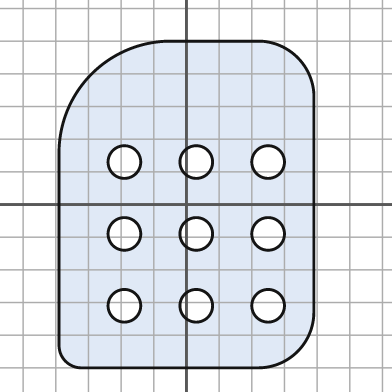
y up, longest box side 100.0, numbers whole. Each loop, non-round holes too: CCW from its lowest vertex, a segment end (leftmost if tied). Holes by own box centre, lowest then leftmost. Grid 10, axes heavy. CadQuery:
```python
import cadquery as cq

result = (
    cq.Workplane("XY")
    .moveTo(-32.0, -50.0)
    .lineTo(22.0, -50.0)
    .threePointArc((34.0, -45.0), (39.0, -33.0))
    .lineTo(39.0, 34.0)
    .threePointArc((34.0, 45.0), (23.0, 50.0))
    .lineTo(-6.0, 50.0)
    .threePointArc((-29.0, 40.0), (-39.0, 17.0))
    .lineTo(-39.0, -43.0)
    .threePointArc((-37.0, -48.0), (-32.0, -50.0))
    .close()
    .moveTo(-19.0, -31.0)
    .circle(5.0)
    .moveTo(3.0, -31.0)
    .circle(5.0)
    .moveTo(25.0, -31.0)
    .circle(5.0)
    .moveTo(-19.0, -9.0)
    .circle(5.0)
    .moveTo(3.0, -9.0)
    .circle(5.0)
    .moveTo(25.0, -9.0)
    .circle(5.0)
    .moveTo(-19.0, 13.0)
    .circle(5.0)
    .moveTo(3.0, 13.0)
    .circle(5.0)
    .moveTo(25.0, 13.0)
    .circle(5.0)
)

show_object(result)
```